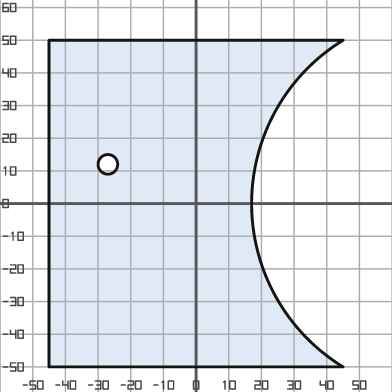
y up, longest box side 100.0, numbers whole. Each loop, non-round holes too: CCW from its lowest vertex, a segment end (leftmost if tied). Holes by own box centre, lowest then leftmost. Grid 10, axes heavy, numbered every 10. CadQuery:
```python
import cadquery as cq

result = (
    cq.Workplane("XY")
    .moveTo(-45.0, -50.0)
    .lineTo(45.0, -50.0)
    .threePointArc((17.0, 0.0), (45.0, 50.0))
    .lineTo(-45.0, 50.0)
    .close()
    .moveTo(-27.0, 12.0)
    .circle(3.0)
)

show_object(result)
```